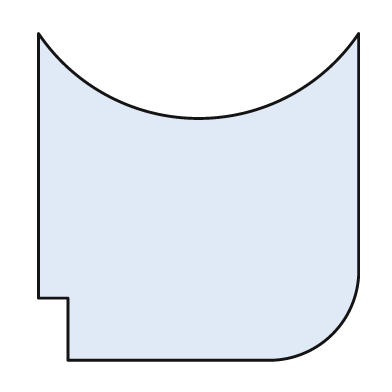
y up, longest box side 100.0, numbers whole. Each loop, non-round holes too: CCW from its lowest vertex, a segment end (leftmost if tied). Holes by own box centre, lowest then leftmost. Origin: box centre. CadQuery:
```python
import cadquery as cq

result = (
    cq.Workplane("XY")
    .moveTo(-40.0, -50.0)
    .lineTo(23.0, -50.0)
    .threePointArc((41.0, -42.0), (49.0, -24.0))
    .lineTo(49.0, 50.0)
    .threePointArc((0.0, 24.0), (-49.0, 50.0))
    .lineTo(-49.0, -31.0)
    .lineTo(-40.0, -31.0)
    .close()
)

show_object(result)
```